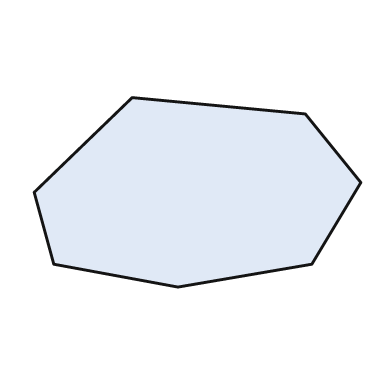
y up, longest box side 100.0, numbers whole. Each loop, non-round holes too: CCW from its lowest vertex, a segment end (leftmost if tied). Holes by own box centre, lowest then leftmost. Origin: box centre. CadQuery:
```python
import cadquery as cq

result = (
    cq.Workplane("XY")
    .moveTo(-6.0, -29.0)
    .lineTo(35.0, -22.0)
    .lineTo(50.0, 3.0)
    .lineTo(33.0, 24.0)
    .lineTo(-20.0, 29.0)
    .lineTo(-50.0, 0.0)
    .lineTo(-44.0, -22.0)
    .close()
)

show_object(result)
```